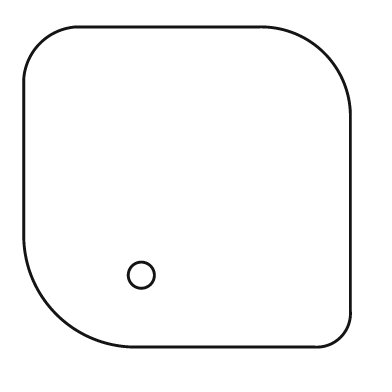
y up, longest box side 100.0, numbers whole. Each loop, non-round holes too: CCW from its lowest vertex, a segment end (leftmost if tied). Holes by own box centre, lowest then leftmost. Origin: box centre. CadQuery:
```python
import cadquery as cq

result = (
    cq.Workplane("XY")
    .moveTo(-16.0, -49.0)
    .lineTo(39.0, -49.0)
    .threePointArc((47.0, -46.0), (50.0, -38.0))
    .lineTo(50.0, 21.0)
    .threePointArc((42.0, 41.0), (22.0, 49.0))
    .lineTo(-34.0, 49.0)
    .threePointArc((-45.0, 44.0), (-50.0, 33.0))
    .lineTo(-50.0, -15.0)
    .threePointArc((-40.0, -39.0), (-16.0, -49.0))
    .close()
    .moveTo(-14.0, -27.0)
    .circle(4.0)
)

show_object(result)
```